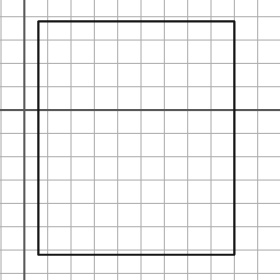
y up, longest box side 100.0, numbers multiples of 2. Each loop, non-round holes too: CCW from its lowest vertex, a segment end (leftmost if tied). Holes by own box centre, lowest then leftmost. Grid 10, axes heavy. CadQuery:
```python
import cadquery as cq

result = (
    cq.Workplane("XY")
    .moveTo(6.0, -62.0)
    .lineTo(90.0, -62.0)
    .lineTo(90.0, 38.0)
    .lineTo(6.0, 38.0)
    .close()
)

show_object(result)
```